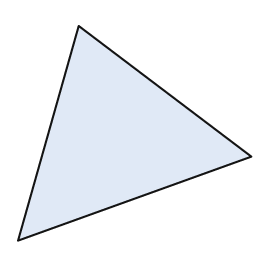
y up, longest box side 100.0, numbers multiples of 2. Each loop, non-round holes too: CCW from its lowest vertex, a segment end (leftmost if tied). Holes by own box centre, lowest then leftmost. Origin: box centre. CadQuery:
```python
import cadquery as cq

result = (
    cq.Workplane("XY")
    .moveTo(-50.0, -46.0)
    .lineTo(50.0, -10.0)
    .lineTo(-24.0, 46.0)
    .close()
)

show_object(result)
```